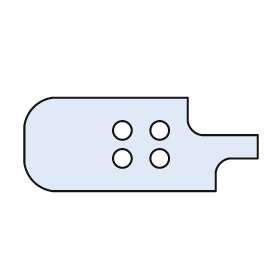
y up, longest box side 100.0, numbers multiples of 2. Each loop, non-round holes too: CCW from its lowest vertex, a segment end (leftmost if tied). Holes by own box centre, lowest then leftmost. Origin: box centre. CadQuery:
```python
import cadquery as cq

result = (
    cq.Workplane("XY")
    .moveTo(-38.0, -20.0)
    .lineTo(32.0, -20.0)
    .lineTo(32.0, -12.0)
    .threePointArc((34.0, -8.0), (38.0, -6.0))
    .lineTo(50.0, -6.0)
    .lineTo(50.0, 4.0)
    .lineTo(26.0, 4.0)
    .threePointArc((22.0, 6.0), (20.0, 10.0))
    .lineTo(20.0, 20.0)
    .lineTo(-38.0, 20.0)
    .threePointArc((-46.0, 16.0), (-50.0, 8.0))
    .lineTo(-50.0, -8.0)
    .threePointArc((-46.0, -16.0), (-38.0, -20.0))
    .close()
    .moveTo(-8.0, -6.0)
    .circle(4.0)
    .moveTo(8.0, -6.0)
    .circle(4.0)
    .moveTo(-8.0, 6.0)
    .circle(4.0)
    .moveTo(8.0, 6.0)
    .circle(4.0)
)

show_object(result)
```